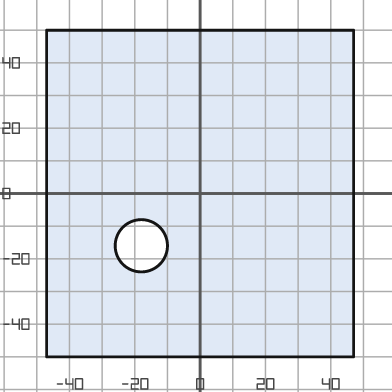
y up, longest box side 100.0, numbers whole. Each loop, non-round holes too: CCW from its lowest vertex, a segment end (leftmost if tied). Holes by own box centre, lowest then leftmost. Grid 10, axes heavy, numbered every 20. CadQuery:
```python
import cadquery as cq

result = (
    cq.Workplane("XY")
    .moveTo(-47.0, -50.0)
    .lineTo(47.0, -50.0)
    .lineTo(47.0, 50.0)
    .lineTo(-47.0, 50.0)
    .close()
    .moveTo(-18.0, -16.0)
    .circle(8.0)
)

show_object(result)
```